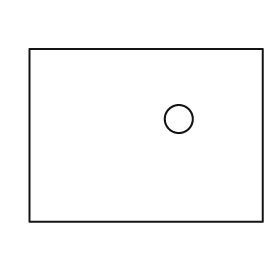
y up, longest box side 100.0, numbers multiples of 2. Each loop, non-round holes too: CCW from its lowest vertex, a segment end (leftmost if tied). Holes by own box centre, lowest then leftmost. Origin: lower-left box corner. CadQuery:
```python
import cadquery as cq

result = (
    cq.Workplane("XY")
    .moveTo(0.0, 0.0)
    .lineTo(100.0, 0.0)
    .lineTo(100.0, 74.0)
    .lineTo(0.0, 74.0)
    .close()
    .moveTo(64.0, 44.0)
    .circle(6.0)
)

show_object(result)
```